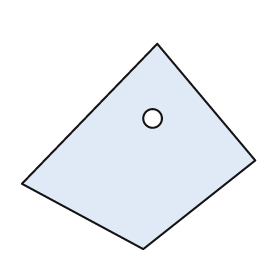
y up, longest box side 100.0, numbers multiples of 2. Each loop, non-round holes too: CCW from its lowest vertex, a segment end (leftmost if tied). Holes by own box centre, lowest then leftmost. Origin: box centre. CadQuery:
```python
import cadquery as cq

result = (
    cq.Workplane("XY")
    .moveTo(2.0, -44.0)
    .lineTo(50.0, -6.0)
    .lineTo(8.0, 44.0)
    .lineTo(-50.0, -16.0)
    .close()
    .moveTo(6.0, 12.0)
    .circle(4.0)
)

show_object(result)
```